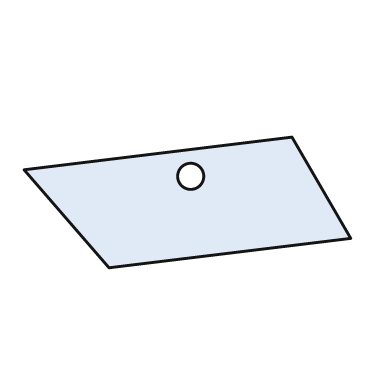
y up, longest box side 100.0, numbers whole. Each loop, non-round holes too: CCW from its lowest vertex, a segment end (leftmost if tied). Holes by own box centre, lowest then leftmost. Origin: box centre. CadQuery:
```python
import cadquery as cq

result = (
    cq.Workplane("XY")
    .moveTo(-24.0, -20.0)
    .lineTo(50.0, -11.0)
    .lineTo(32.0, 20.0)
    .lineTo(-50.0, 10.0)
    .close()
    .moveTo(1.0, 8.0)
    .circle(4.0)
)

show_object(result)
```